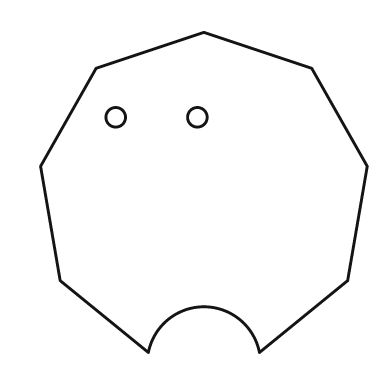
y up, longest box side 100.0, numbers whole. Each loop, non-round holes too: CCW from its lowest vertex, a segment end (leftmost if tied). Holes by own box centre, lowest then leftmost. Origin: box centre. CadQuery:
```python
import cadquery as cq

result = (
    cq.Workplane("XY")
    .moveTo(-17.0, -49.0)
    .threePointArc((0.0, -35.0), (17.0, -49.0))
    .lineTo(44.0, -27.0)
    .lineTo(50.0, 8.0)
    .lineTo(33.0, 38.0)
    .lineTo(0.0, 49.0)
    .lineTo(-33.0, 38.0)
    .lineTo(-50.0, 8.0)
    .lineTo(-44.0, -27.0)
    .close()
    .moveTo(-27.0, 23.0)
    .circle(3.0)
    .moveTo(-2.0, 23.0)
    .circle(3.0)
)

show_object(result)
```